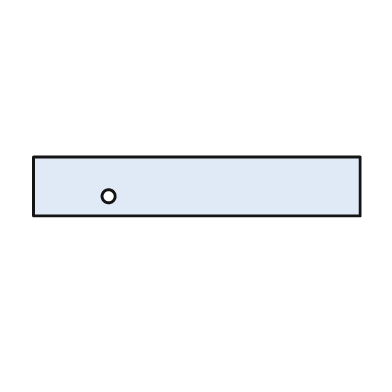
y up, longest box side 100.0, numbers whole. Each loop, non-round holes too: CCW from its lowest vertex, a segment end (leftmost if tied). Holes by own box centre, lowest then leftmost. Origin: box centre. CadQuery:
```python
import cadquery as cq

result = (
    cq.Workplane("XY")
    .moveTo(-50.0, -9.0)
    .lineTo(50.0, -9.0)
    .lineTo(50.0, 9.0)
    .lineTo(-50.0, 9.0)
    .close()
    .moveTo(-27.0, -3.0)
    .circle(2.0)
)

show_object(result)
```